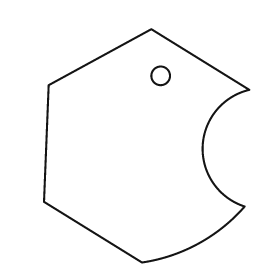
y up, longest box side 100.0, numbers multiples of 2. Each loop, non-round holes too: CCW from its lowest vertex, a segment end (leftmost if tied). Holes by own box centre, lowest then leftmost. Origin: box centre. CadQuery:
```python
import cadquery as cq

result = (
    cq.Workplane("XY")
    .moveTo(-2.0, -50.0)
    .threePointArc((22.0, -42.0), (42.0, -26.0))
    .threePointArc((24.0, 0.0), (44.0, 24.0))
    .lineTo(2.0, 50.0)
    .lineTo(-42.0, 26.0)
    .lineTo(-44.0, -24.0)
    .close()
    .moveTo(6.0, 30.0)
    .circle(4.0)
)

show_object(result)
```